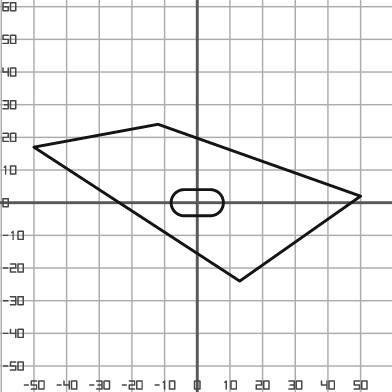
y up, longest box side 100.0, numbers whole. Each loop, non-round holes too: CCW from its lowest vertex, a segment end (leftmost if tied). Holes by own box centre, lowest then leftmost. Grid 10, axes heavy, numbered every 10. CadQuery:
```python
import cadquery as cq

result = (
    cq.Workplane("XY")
    .moveTo(13.0, -24.0)
    .lineTo(50.0, 2.0)
    .lineTo(-12.0, 24.0)
    .lineTo(-50.0, 17.0)
    .close()
    .moveTo(-4.0, -4.0)
    .lineTo(4.0, -4.0)
    .threePointArc((8.0, 0.0), (4.0, 4.0))
    .lineTo(-4.0, 4.0)
    .threePointArc((-8.0, 0.0), (-4.0, -4.0))
    .close()
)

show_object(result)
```